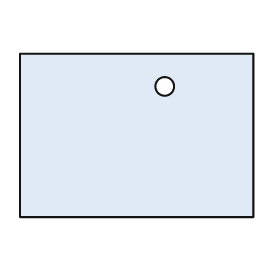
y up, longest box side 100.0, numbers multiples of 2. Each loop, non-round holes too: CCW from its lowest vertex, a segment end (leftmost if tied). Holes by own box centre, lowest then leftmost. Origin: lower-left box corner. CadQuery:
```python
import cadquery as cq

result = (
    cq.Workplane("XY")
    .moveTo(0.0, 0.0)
    .lineTo(100.0, 0.0)
    .lineTo(100.0, 70.0)
    .lineTo(0.0, 70.0)
    .close()
    .moveTo(62.0, 56.0)
    .circle(4.0)
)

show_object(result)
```